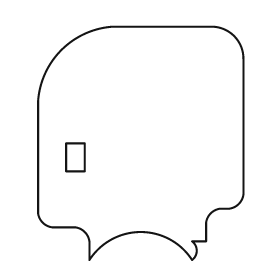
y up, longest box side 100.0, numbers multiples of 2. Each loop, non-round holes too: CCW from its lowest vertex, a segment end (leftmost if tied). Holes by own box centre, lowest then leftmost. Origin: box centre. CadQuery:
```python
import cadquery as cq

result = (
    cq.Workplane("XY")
    .moveTo(-22.0, -50.0)
    .threePointArc((0.0, -38.0), (22.0, -50.0))
    .threePointArc((24.0, -46.0), (22.0, -42.0))
    .lineTo(28.0, -42.0)
    .lineTo(28.0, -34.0)
    .threePointArc((30.0, -30.0), (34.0, -28.0))
    .lineTo(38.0, -28.0)
    .threePointArc((42.0, -26.0), (44.0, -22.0))
    .lineTo(44.0, 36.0)
    .threePointArc((40.0, 46.0), (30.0, 50.0))
    .lineTo(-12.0, 50.0)
    .threePointArc((-34.0, 40.0), (-44.0, 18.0))
    .lineTo(-44.0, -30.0)
    .threePointArc((-42.0, -34.0), (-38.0, -36.0))
    .lineTo(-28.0, -36.0)
    .threePointArc((-24.0, -38.0), (-22.0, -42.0))
    .close()
    .moveTo(-32.0, -12.0)
    .lineTo(-24.0, -12.0)
    .lineTo(-24.0, 0.0)
    .lineTo(-32.0, 0.0)
    .close()
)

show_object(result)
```